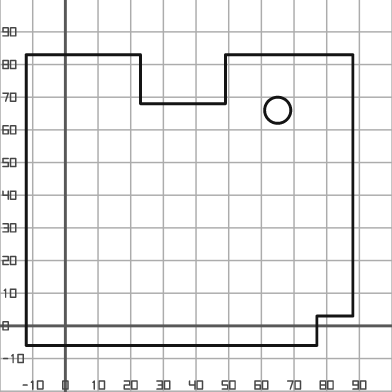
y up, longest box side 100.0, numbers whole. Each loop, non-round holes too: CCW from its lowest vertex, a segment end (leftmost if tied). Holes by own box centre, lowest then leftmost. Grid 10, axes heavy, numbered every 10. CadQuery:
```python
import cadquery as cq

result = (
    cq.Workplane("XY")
    .moveTo(-12.0, -6.0)
    .lineTo(77.0, -6.0)
    .lineTo(77.0, 3.0)
    .lineTo(88.0, 3.0)
    .lineTo(88.0, 83.0)
    .lineTo(49.0, 83.0)
    .lineTo(49.0, 68.0)
    .lineTo(23.0, 68.0)
    .lineTo(23.0, 83.0)
    .lineTo(-12.0, 83.0)
    .close()
    .moveTo(65.0, 66.0)
    .circle(4.0)
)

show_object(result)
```